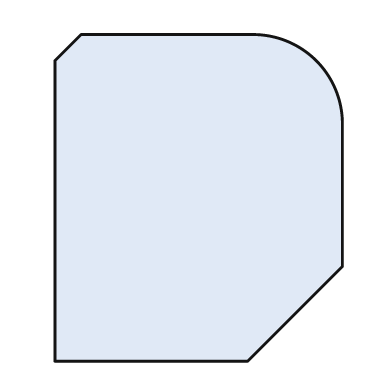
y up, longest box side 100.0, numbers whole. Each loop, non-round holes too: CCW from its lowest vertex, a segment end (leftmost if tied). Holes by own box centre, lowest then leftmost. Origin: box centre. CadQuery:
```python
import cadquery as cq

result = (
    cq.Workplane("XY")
    .moveTo(-44.0, -50.0)
    .lineTo(15.0, -50.0)
    .lineTo(44.0, -21.0)
    .lineTo(44.0, 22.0)
    .threePointArc((36.0, 42.0), (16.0, 50.0))
    .lineTo(-36.0, 50.0)
    .lineTo(-44.0, 42.0)
    .close()
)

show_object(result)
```